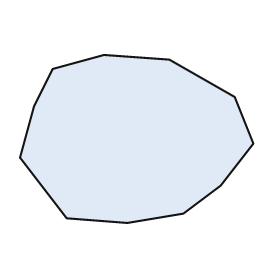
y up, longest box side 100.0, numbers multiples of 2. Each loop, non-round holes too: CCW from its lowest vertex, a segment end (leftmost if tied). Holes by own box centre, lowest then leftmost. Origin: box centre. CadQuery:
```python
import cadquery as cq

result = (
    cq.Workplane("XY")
    .moveTo(-4.0, -36.0)
    .lineTo(20.0, -32.0)
    .lineTo(36.0, -20.0)
    .lineTo(50.0, -2.0)
    .lineTo(42.0, 18.0)
    .lineTo(14.0, 34.0)
    .lineTo(-14.0, 36.0)
    .lineTo(-36.0, 30.0)
    .lineTo(-44.0, 14.0)
    .lineTo(-50.0, -8.0)
    .lineTo(-30.0, -34.0)
    .close()
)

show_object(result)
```